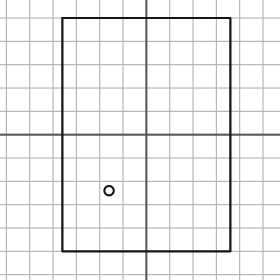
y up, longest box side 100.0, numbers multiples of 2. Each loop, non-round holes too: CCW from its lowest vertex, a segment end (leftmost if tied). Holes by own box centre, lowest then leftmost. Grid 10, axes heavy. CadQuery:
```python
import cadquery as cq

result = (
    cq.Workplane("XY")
    .moveTo(-36.0, -50.0)
    .lineTo(36.0, -50.0)
    .lineTo(36.0, 50.0)
    .lineTo(-36.0, 50.0)
    .close()
    .moveTo(-16.0, -24.0)
    .circle(2.0)
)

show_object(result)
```